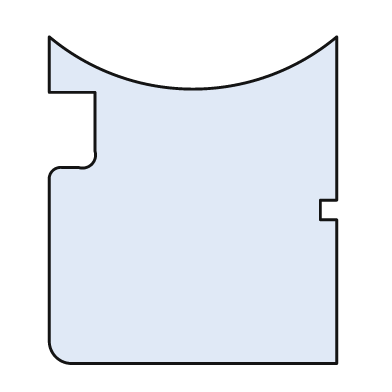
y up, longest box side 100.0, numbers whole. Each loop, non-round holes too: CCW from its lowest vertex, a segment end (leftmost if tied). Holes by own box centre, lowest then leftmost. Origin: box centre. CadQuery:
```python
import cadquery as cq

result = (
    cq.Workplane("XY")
    .moveTo(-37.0, -50.0)
    .lineTo(44.0, -50.0)
    .lineTo(44.0, -6.0)
    .lineTo(39.0, -6.0)
    .lineTo(39.0, 0.0)
    .lineTo(44.0, 0.0)
    .lineTo(44.0, 50.0)
    .threePointArc((0.0, 34.0), (-44.0, 50.0))
    .lineTo(-44.0, 33.0)
    .lineTo(-30.0, 33.0)
    .lineTo(-30.0, 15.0)
    .threePointArc((-31.0, 11.0), (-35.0, 10.0))
    .lineTo(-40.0, 10.0)
    .threePointArc((-43.0, 9.0), (-44.0, 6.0))
    .lineTo(-44.0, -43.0)
    .threePointArc((-42.0, -48.0), (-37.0, -50.0))
    .close()
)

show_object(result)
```